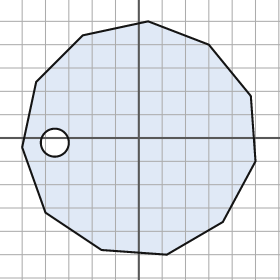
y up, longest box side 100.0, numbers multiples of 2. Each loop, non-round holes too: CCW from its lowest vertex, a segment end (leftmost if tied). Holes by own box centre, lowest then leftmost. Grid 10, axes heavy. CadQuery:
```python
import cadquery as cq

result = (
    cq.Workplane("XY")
    .moveTo(12.0, -50.0)
    .lineTo(36.0, -36.0)
    .lineTo(50.0, -10.0)
    .lineTo(48.0, 18.0)
    .lineTo(30.0, 40.0)
    .lineTo(4.0, 50.0)
    .lineTo(-24.0, 44.0)
    .lineTo(-44.0, 24.0)
    .lineTo(-50.0, -4.0)
    .lineTo(-40.0, -32.0)
    .lineTo(-16.0, -48.0)
    .close()
    .moveTo(-36.0, -2.0)
    .circle(6.0)
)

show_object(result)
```